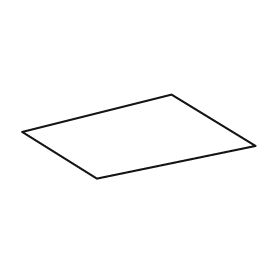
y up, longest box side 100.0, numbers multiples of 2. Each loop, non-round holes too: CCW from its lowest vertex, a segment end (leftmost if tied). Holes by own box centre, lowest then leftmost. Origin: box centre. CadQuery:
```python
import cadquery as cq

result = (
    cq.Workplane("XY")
    .moveTo(-18.0, -18.0)
    .lineTo(50.0, -4.0)
    .lineTo(14.0, 18.0)
    .lineTo(-50.0, 2.0)
    .close()
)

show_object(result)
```